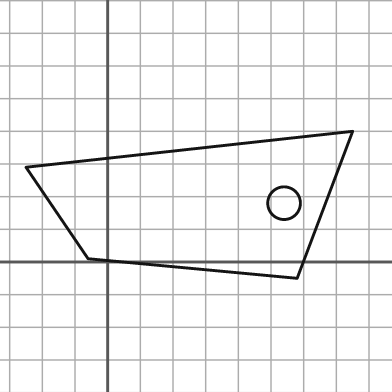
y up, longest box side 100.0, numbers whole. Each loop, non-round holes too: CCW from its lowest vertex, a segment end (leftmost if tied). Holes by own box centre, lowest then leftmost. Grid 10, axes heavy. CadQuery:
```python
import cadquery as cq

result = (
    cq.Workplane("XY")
    .moveTo(58.0, -5.0)
    .lineTo(75.0, 40.0)
    .lineTo(-25.0, 29.0)
    .lineTo(-6.0, 1.0)
    .close()
    .moveTo(54.0, 18.0)
    .circle(5.0)
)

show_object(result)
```